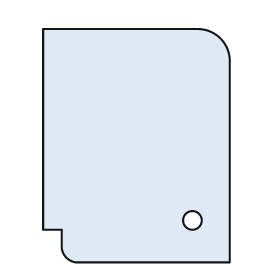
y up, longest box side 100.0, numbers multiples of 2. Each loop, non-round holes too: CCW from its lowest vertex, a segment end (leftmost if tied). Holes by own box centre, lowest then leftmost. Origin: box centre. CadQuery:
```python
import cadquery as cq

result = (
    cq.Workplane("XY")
    .moveTo(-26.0, -50.0)
    .lineTo(40.0, -50.0)
    .lineTo(40.0, 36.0)
    .threePointArc((36.0, 46.0), (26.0, 50.0))
    .lineTo(-40.0, 50.0)
    .lineTo(-40.0, -36.0)
    .lineTo(-32.0, -36.0)
    .lineTo(-32.0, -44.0)
    .threePointArc((-30.0, -48.0), (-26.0, -50.0))
    .close()
    .moveTo(24.0, -32.0)
    .circle(4.0)
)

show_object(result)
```